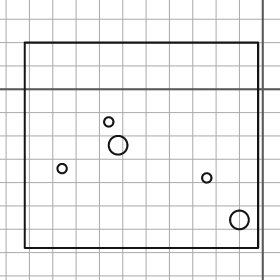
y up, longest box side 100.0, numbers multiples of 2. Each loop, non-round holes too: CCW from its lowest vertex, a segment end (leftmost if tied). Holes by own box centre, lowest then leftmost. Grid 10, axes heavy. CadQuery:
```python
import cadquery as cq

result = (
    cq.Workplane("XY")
    .moveTo(-102.0, -68.0)
    .lineTo(-2.0, -68.0)
    .lineTo(-2.0, 20.0)
    .lineTo(-102.0, 20.0)
    .close()
    .moveTo(-10.0, -56.0)
    .circle(4.0)
    .moveTo(-24.0, -38.0)
    .circle(2.0)
    .moveTo(-86.0, -34.0)
    .circle(2.0)
    .moveTo(-62.0, -24.0)
    .circle(4.0)
    .moveTo(-66.0, -14.0)
    .circle(2.0)
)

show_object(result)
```